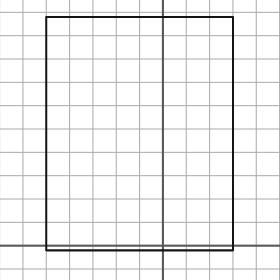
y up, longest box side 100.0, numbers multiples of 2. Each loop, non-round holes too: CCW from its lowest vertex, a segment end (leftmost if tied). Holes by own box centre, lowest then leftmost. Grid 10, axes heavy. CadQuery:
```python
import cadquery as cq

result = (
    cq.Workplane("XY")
    .moveTo(-50.0, -2.0)
    .lineTo(30.0, -2.0)
    .lineTo(30.0, 98.0)
    .lineTo(-50.0, 98.0)
    .close()
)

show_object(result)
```